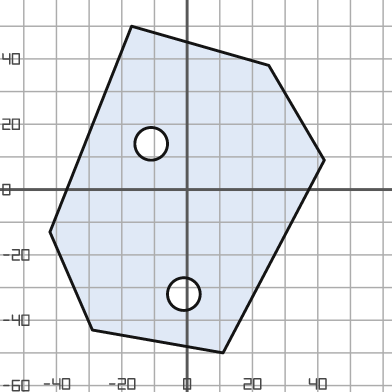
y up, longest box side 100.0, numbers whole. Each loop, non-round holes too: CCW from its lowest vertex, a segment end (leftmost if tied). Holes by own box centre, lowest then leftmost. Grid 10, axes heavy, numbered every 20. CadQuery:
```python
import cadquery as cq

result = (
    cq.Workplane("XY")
    .moveTo(11.0, -50.0)
    .lineTo(42.0, 9.0)
    .lineTo(25.0, 38.0)
    .lineTo(-17.0, 50.0)
    .lineTo(-42.0, -13.0)
    .lineTo(-29.0, -43.0)
    .close()
    .moveTo(-1.0, -32.0)
    .circle(5.0)
    .moveTo(-11.0, 14.0)
    .circle(5.0)
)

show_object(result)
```